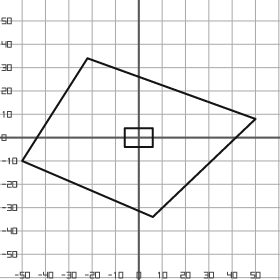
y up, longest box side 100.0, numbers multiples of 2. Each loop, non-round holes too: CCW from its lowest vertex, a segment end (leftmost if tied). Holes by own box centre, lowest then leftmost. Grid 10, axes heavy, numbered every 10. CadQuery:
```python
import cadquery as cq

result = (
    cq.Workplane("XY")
    .moveTo(6.0, -34.0)
    .lineTo(50.0, 8.0)
    .lineTo(-22.0, 34.0)
    .lineTo(-50.0, -10.0)
    .close()
    .moveTo(-6.0, -4.0)
    .lineTo(6.0, -4.0)
    .lineTo(6.0, 4.0)
    .lineTo(-6.0, 4.0)
    .close()
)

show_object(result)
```